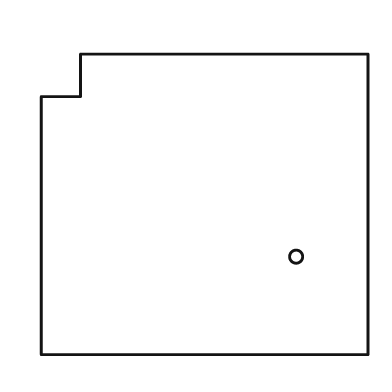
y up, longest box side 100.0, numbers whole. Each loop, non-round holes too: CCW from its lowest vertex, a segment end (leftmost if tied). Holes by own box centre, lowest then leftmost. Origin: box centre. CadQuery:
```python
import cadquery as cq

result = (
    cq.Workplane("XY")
    .moveTo(-50.0, -46.0)
    .lineTo(50.0, -46.0)
    .lineTo(50.0, 46.0)
    .lineTo(-38.0, 46.0)
    .lineTo(-38.0, 33.0)
    .lineTo(-50.0, 33.0)
    .close()
    .moveTo(28.0, -16.0)
    .circle(2.0)
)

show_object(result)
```